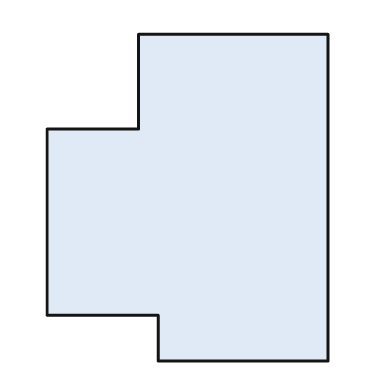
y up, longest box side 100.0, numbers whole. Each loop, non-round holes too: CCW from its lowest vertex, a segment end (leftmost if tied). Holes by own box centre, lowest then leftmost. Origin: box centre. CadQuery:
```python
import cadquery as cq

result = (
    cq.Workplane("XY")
    .moveTo(-9.0, -50.0)
    .lineTo(43.0, -50.0)
    .lineTo(43.0, 50.0)
    .lineTo(-15.0, 50.0)
    .lineTo(-15.0, 21.0)
    .lineTo(-43.0, 21.0)
    .lineTo(-43.0, -36.0)
    .lineTo(-9.0, -36.0)
    .close()
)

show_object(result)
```